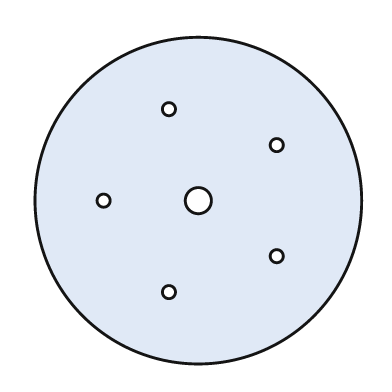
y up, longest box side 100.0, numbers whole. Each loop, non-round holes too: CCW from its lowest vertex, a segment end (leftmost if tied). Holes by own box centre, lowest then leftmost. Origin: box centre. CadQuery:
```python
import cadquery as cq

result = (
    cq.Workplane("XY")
    .moveTo(0.0, 0.0)
    .circle(50.0)
    .moveTo(-9.0, -28.0)
    .circle(2.0)
    .moveTo(24.0, -17.0)
    .circle(2.0)
    .moveTo(-29.0, 0.0)
    .circle(2.0)
    .moveTo(0.0, 0.0)
    .circle(4.0)
    .moveTo(24.0, 17.0)
    .circle(2.0)
    .moveTo(-9.0, 28.0)
    .circle(2.0)
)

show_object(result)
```